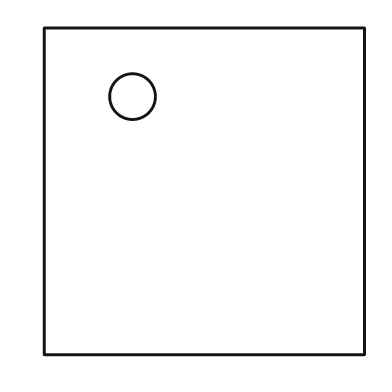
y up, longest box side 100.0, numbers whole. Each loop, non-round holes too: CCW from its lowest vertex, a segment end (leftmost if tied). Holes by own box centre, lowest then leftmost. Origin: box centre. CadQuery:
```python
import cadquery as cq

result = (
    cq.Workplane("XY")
    .moveTo(-49.0, -50.0)
    .lineTo(49.0, -50.0)
    .lineTo(49.0, 50.0)
    .lineTo(-49.0, 50.0)
    .close()
    .moveTo(-22.0, 29.0)
    .circle(7.0)
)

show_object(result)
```